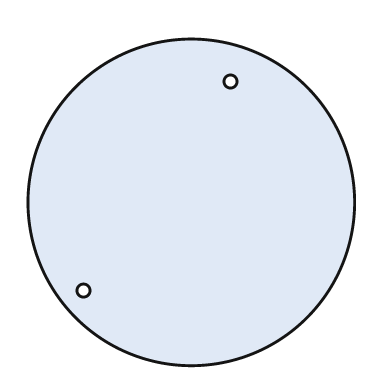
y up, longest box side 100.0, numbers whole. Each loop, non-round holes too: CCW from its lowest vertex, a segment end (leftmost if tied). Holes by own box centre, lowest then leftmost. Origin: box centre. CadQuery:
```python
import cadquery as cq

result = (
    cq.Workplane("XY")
    .moveTo(0.0, 0.0)
    .circle(50.0)
    .moveTo(-33.0, -27.0)
    .circle(2.0)
    .moveTo(12.0, 37.0)
    .circle(2.0)
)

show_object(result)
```